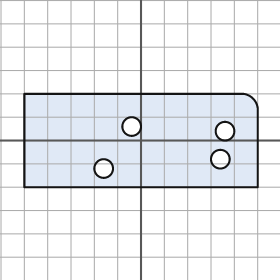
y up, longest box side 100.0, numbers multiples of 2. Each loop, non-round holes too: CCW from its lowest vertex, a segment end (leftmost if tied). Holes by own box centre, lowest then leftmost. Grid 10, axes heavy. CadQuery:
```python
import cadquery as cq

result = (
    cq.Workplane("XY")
    .moveTo(-50.0, -20.0)
    .lineTo(50.0, -20.0)
    .lineTo(50.0, 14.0)
    .threePointArc((48.0, 18.0), (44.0, 20.0))
    .lineTo(-50.0, 20.0)
    .close()
    .moveTo(-16.0, -12.0)
    .circle(4.0)
    .moveTo(34.0, -8.0)
    .circle(4.0)
    .moveTo(36.0, 4.0)
    .circle(4.0)
    .moveTo(-4.0, 6.0)
    .circle(4.0)
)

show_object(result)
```